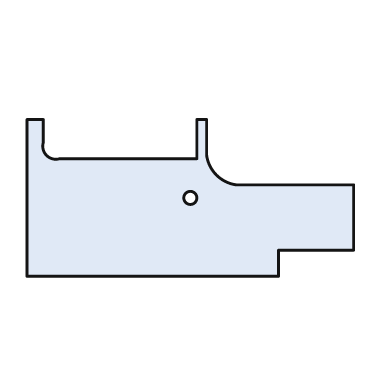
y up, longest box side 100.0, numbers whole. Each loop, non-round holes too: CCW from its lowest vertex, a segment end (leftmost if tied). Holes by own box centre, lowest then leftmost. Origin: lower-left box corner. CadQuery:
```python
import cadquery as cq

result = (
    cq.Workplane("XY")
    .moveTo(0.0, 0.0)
    .lineTo(77.0, 0.0)
    .lineTo(77.0, 8.0)
    .lineTo(100.0, 8.0)
    .lineTo(100.0, 28.0)
    .lineTo(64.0, 28.0)
    .threePointArc((58.0, 31.0), (55.0, 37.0))
    .lineTo(55.0, 48.0)
    .lineTo(52.0, 48.0)
    .lineTo(52.0, 36.0)
    .lineTo(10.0, 36.0)
    .threePointArc((6.0, 37.0), (5.0, 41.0))
    .lineTo(5.0, 48.0)
    .lineTo(0.0, 48.0)
    .close()
    .moveTo(50.0, 24.0)
    .circle(2.0)
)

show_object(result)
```